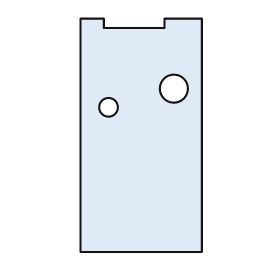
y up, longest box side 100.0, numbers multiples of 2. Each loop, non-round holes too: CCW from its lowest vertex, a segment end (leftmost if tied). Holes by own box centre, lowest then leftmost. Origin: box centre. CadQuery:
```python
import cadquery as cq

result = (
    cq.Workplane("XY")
    .moveTo(-26.0, -50.0)
    .lineTo(26.0, -50.0)
    .lineTo(26.0, 50.0)
    .lineTo(10.0, 50.0)
    .lineTo(10.0, 46.0)
    .lineTo(-16.0, 46.0)
    .lineTo(-16.0, 50.0)
    .lineTo(-26.0, 50.0)
    .close()
    .moveTo(-14.0, 12.0)
    .circle(4.0)
    .moveTo(14.0, 20.0)
    .circle(6.0)
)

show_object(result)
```